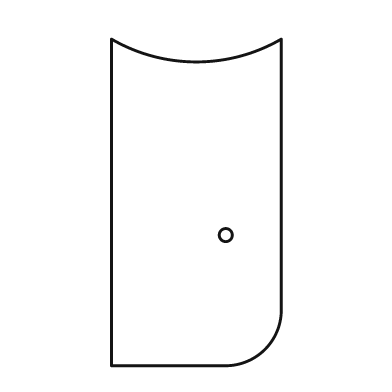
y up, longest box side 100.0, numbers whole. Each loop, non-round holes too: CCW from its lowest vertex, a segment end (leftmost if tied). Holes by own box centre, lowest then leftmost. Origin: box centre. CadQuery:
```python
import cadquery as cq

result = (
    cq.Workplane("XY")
    .moveTo(-26.0, -50.0)
    .lineTo(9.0, -50.0)
    .threePointArc((21.0, -45.0), (26.0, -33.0))
    .lineTo(26.0, 50.0)
    .threePointArc((0.0, 43.0), (-26.0, 50.0))
    .close()
    .moveTo(9.0, -10.0)
    .circle(2.0)
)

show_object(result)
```